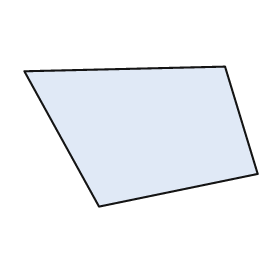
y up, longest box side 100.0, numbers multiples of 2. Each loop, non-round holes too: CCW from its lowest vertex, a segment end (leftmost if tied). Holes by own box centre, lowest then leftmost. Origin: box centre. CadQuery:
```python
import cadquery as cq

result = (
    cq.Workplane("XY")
    .moveTo(-18.0, -30.0)
    .lineTo(50.0, -16.0)
    .lineTo(36.0, 30.0)
    .lineTo(-50.0, 28.0)
    .close()
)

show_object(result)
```